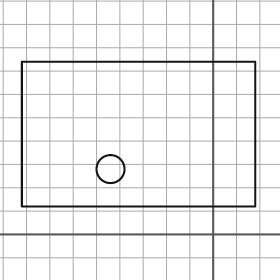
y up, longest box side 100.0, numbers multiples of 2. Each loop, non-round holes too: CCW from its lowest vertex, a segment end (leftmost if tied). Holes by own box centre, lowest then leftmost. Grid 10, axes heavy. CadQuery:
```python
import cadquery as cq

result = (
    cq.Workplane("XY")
    .moveTo(-82.0, 12.0)
    .lineTo(18.0, 12.0)
    .lineTo(18.0, 74.0)
    .lineTo(-82.0, 74.0)
    .close()
    .moveTo(-44.0, 28.0)
    .circle(6.0)
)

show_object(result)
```